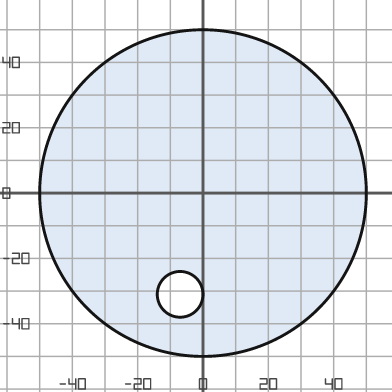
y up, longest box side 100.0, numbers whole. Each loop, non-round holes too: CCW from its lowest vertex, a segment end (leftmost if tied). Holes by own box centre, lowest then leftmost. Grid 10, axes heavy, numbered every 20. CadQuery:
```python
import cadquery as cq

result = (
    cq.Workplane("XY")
    .moveTo(0.0, 0.0)
    .circle(50.0)
    .moveTo(-7.0, -31.0)
    .circle(7.0)
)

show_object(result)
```